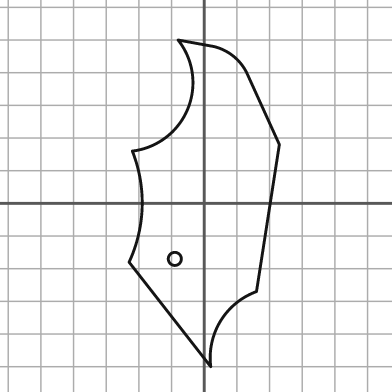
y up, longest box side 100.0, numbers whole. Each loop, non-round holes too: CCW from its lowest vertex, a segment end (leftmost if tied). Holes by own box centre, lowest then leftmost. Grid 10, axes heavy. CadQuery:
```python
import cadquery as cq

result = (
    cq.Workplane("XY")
    .moveTo(2.0, -50.0)
    .threePointArc((5.0, -36.0), (16.0, -27.0))
    .lineTo(23.0, 18.0)
    .lineTo(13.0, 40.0)
    .threePointArc((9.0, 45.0), (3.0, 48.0))
    .lineTo(-8.0, 50.0)
    .threePointArc((-5.0, 29.0), (-22.0, 16.0))
    .threePointArc((-19.0, -1.0), (-23.0, -18.0))
    .close()
    .moveTo(-9.0, -17.0)
    .circle(2.0)
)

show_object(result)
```